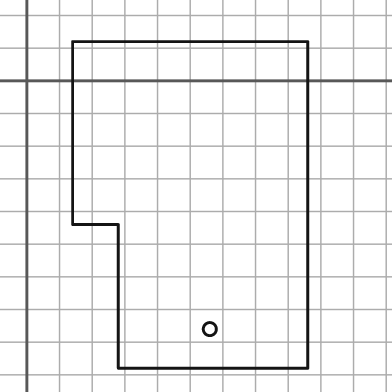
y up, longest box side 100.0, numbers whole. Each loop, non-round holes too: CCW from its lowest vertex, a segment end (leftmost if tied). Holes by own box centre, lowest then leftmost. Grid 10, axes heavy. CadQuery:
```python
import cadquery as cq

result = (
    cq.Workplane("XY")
    .moveTo(28.0, -88.0)
    .lineTo(86.0, -88.0)
    .lineTo(86.0, 12.0)
    .lineTo(14.0, 12.0)
    .lineTo(14.0, -44.0)
    .lineTo(28.0, -44.0)
    .close()
    .moveTo(56.0, -76.0)
    .circle(2.0)
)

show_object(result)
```